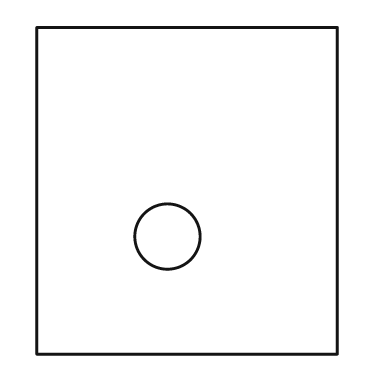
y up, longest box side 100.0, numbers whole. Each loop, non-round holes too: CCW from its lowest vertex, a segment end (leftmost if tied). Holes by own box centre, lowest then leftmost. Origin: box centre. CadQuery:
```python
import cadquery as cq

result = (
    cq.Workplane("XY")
    .moveTo(-46.0, -50.0)
    .lineTo(46.0, -50.0)
    .lineTo(46.0, 50.0)
    .lineTo(-46.0, 50.0)
    .close()
    .moveTo(-6.0, -14.0)
    .circle(10.0)
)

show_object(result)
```